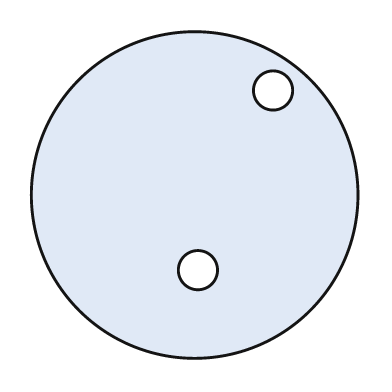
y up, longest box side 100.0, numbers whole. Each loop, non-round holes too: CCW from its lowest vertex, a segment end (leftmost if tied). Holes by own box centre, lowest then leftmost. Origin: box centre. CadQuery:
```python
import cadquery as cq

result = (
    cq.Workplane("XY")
    .moveTo(0.0, 0.0)
    .circle(50.0)
    .moveTo(1.0, -23.0)
    .circle(6.0)
    .moveTo(24.0, 32.0)
    .circle(6.0)
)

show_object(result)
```